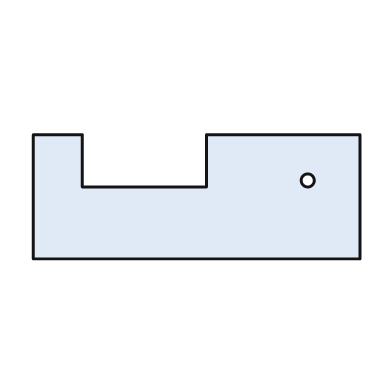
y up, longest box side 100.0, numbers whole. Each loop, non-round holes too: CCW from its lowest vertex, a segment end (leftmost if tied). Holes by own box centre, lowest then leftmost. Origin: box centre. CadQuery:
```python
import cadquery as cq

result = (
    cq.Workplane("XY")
    .moveTo(-50.0, -19.0)
    .lineTo(50.0, -19.0)
    .lineTo(50.0, 19.0)
    .lineTo(3.0, 19.0)
    .lineTo(3.0, 3.0)
    .lineTo(-35.0, 3.0)
    .lineTo(-35.0, 19.0)
    .lineTo(-50.0, 19.0)
    .close()
    .moveTo(34.0, 5.0)
    .circle(2.0)
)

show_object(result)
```